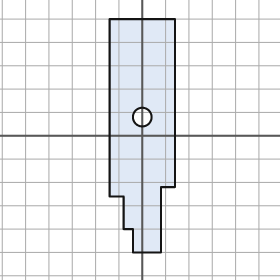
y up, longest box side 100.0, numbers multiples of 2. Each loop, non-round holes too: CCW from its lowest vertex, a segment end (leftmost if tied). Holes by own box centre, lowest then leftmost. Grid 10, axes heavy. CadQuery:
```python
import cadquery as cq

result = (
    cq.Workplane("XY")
    .moveTo(-4.0, -50.0)
    .lineTo(8.0, -50.0)
    .lineTo(8.0, -22.0)
    .lineTo(14.0, -22.0)
    .lineTo(14.0, 50.0)
    .lineTo(-14.0, 50.0)
    .lineTo(-14.0, -26.0)
    .lineTo(-8.0, -26.0)
    .lineTo(-8.0, -40.0)
    .lineTo(-4.0, -40.0)
    .close()
    .moveTo(0.0, 8.0)
    .circle(4.0)
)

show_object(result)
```